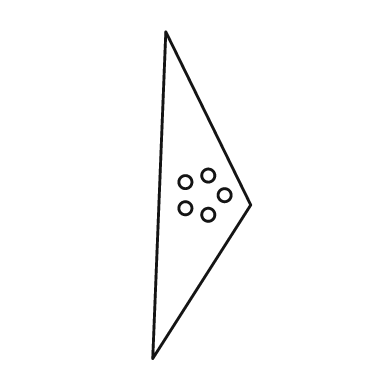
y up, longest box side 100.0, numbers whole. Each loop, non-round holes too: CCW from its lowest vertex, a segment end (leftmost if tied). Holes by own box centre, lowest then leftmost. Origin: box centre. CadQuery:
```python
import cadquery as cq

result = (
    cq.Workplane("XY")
    .moveTo(-15.0, -50.0)
    .lineTo(15.0, -3.0)
    .lineTo(-11.0, 50.0)
    .close()
    .moveTo(2.0, -6.0)
    .circle(2.0)
    .moveTo(-5.0, -4.0)
    .circle(2.0)
    .moveTo(7.0, 0.0)
    .circle(2.0)
    .moveTo(-5.0, 4.0)
    .circle(2.0)
    .moveTo(2.0, 6.0)
    .circle(2.0)
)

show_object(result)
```